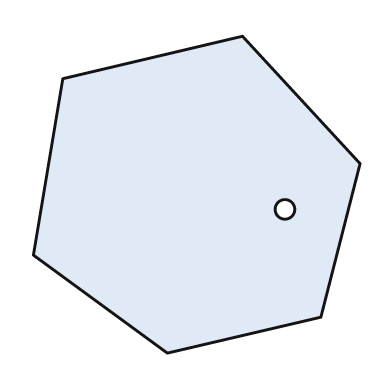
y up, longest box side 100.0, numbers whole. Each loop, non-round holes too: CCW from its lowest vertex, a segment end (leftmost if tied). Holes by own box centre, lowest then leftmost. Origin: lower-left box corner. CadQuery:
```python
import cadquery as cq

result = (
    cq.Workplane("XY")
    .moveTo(41.0, 0.0)
    .lineTo(88.0, 11.0)
    .lineTo(100.0, 58.0)
    .lineTo(64.0, 97.0)
    .lineTo(9.0, 84.0)
    .lineTo(0.0, 30.0)
    .close()
    .moveTo(77.0, 44.0)
    .circle(3.0)
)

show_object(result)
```